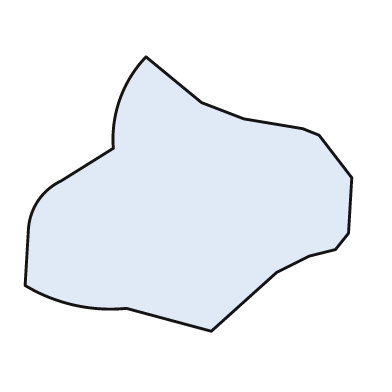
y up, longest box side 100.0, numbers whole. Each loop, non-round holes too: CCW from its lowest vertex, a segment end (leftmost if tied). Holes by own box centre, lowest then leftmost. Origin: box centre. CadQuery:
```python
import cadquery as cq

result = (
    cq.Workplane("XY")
    .moveTo(7.0, -42.0)
    .lineTo(27.0, -24.0)
    .lineTo(37.0, -19.0)
    .lineTo(45.0, -17.0)
    .lineTo(49.0, -12.0)
    .lineTo(50.0, 5.0)
    .lineTo(40.0, 18.0)
    .lineTo(35.0, 20.0)
    .lineTo(17.0, 23.0)
    .lineTo(4.0, 28.0)
    .lineTo(-13.0, 42.0)
    .threePointArc((-21.0, 29.0), (-23.0, 14.0))
    .lineTo(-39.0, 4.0)
    .threePointArc((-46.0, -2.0), (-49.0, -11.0))
    .lineTo(-50.0, -28.0)
    .threePointArc((-35.0, -34.0), (-19.0, -35.0))
    .close()
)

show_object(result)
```